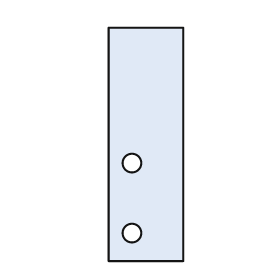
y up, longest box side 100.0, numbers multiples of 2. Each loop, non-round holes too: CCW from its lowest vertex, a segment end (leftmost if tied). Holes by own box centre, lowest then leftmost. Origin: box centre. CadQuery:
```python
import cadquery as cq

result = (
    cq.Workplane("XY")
    .moveTo(-16.0, -50.0)
    .lineTo(16.0, -50.0)
    .lineTo(16.0, 50.0)
    .lineTo(-16.0, 50.0)
    .close()
    .moveTo(-6.0, -38.0)
    .circle(4.0)
    .moveTo(-6.0, -8.0)
    .circle(4.0)
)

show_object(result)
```